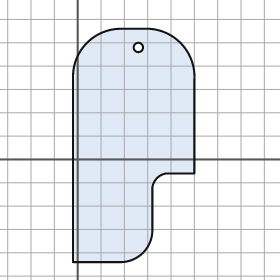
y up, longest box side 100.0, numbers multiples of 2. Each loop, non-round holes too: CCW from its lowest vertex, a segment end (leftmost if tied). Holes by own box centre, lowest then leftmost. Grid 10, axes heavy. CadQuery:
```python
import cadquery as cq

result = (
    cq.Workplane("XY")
    .moveTo(-2.0, -44.0)
    .lineTo(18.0, -44.0)
    .threePointArc((28.0, -40.0), (32.0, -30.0))
    .lineTo(32.0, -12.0)
    .threePointArc((34.0, -8.0), (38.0, -6.0))
    .lineTo(50.0, -6.0)
    .lineTo(50.0, 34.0)
    .threePointArc((44.0, 50.0), (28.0, 56.0))
    .lineTo(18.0, 56.0)
    .threePointArc((4.0, 50.0), (-2.0, 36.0))
    .close()
    .moveTo(26.0, 48.0)
    .circle(2.0)
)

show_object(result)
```